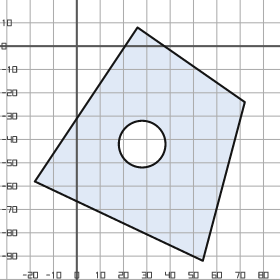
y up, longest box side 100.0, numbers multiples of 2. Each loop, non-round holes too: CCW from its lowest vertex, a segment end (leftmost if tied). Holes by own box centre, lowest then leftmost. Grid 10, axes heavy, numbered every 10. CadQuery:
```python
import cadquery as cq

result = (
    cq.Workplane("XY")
    .moveTo(54.0, -92.0)
    .lineTo(72.0, -24.0)
    .lineTo(26.0, 8.0)
    .lineTo(-18.0, -58.0)
    .close()
    .moveTo(28.0, -42.0)
    .circle(10.0)
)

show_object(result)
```